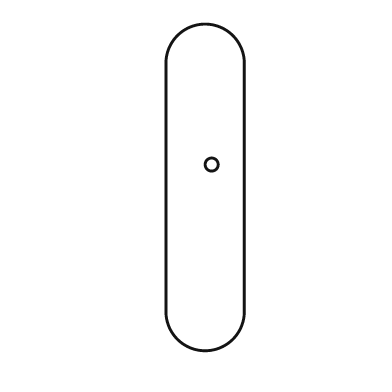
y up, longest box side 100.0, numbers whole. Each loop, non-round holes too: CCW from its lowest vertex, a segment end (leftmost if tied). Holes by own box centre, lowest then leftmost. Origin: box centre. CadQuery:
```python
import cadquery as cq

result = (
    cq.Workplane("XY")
    .moveTo(-12.0, -38.0)
    .threePointArc((0.0, -50.0), (12.0, -38.0))
    .lineTo(12.0, 38.0)
    .threePointArc((0.0, 50.0), (-12.0, 38.0))
    .close()
    .moveTo(2.0, 7.0)
    .circle(2.0)
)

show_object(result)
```